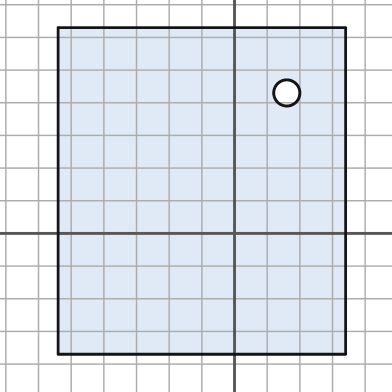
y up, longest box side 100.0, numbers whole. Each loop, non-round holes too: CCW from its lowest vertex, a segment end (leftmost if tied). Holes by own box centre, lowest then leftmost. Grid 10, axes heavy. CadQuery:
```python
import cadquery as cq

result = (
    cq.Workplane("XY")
    .moveTo(-54.0, -37.0)
    .lineTo(34.0, -37.0)
    .lineTo(34.0, 63.0)
    .lineTo(-54.0, 63.0)
    .close()
    .moveTo(16.0, 43.0)
    .circle(4.0)
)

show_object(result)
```